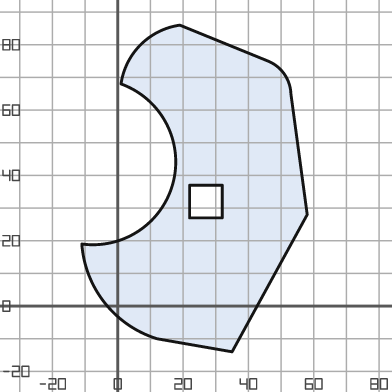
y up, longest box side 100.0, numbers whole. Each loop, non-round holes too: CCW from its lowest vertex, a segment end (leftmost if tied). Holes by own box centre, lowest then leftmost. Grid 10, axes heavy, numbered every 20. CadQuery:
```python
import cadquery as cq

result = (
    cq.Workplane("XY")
    .moveTo(35.0, -14.0)
    .lineTo(58.0, 28.0)
    .lineTo(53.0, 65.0)
    .threePointArc((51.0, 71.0), (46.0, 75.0))
    .lineTo(19.0, 86.0)
    .threePointArc((7.0, 80.0), (1.0, 68.0))
    .threePointArc((17.0, 38.0), (-11.0, 19.0))
    .threePointArc((-4.0, 1.0), (12.0, -10.0))
    .close()
    .moveTo(22.0, 27.0)
    .lineTo(32.0, 27.0)
    .lineTo(32.0, 37.0)
    .lineTo(22.0, 37.0)
    .close()
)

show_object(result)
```